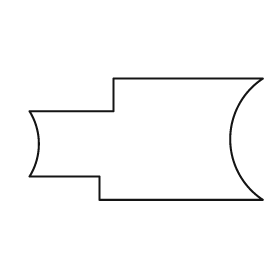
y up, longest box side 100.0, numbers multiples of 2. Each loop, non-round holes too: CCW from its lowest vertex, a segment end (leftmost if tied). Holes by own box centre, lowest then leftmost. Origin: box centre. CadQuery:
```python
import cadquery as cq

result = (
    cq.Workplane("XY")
    .moveTo(-20.0, -26.0)
    .lineTo(50.0, -26.0)
    .threePointArc((36.0, 0.0), (50.0, 26.0))
    .lineTo(-14.0, 26.0)
    .lineTo(-14.0, 12.0)
    .lineTo(-50.0, 12.0)
    .threePointArc((-46.0, -2.0), (-50.0, -16.0))
    .lineTo(-20.0, -16.0)
    .close()
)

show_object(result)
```